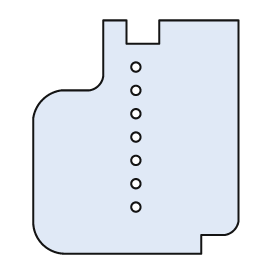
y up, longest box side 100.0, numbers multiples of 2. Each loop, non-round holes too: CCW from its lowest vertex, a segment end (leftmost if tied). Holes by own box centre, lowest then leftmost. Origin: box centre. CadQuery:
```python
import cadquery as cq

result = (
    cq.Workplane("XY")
    .moveTo(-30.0, -50.0)
    .lineTo(28.0, -50.0)
    .lineTo(28.0, -42.0)
    .lineTo(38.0, -42.0)
    .threePointArc((42.0, -40.0), (44.0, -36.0))
    .lineTo(44.0, 50.0)
    .lineTo(10.0, 50.0)
    .lineTo(10.0, 40.0)
    .lineTo(-4.0, 40.0)
    .lineTo(-4.0, 50.0)
    .lineTo(-14.0, 50.0)
    .lineTo(-14.0, 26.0)
    .threePointArc((-16.0, 22.0), (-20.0, 20.0))
    .lineTo(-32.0, 20.0)
    .threePointArc((-40.0, 16.0), (-44.0, 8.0))
    .lineTo(-44.0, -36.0)
    .threePointArc((-40.0, -46.0), (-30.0, -50.0))
    .close()
    .moveTo(0.0, -30.0)
    .circle(2.0)
    .moveTo(0.0, -20.0)
    .circle(2.0)
    .moveTo(0.0, -10.0)
    .circle(2.0)
    .moveTo(0.0, 0.0)
    .circle(2.0)
    .moveTo(0.0, 10.0)
    .circle(2.0)
    .moveTo(0.0, 20.0)
    .circle(2.0)
    .moveTo(0.0, 30.0)
    .circle(2.0)
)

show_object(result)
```